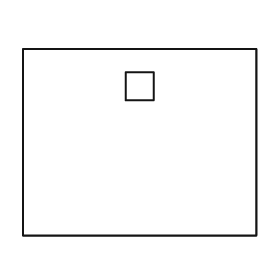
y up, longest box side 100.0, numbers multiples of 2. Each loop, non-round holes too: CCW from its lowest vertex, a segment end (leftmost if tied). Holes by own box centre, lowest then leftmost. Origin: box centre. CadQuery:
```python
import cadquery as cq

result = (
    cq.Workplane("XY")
    .moveTo(-50.0, -40.0)
    .lineTo(50.0, -40.0)
    .lineTo(50.0, 40.0)
    .lineTo(-50.0, 40.0)
    .close()
    .moveTo(-6.0, 18.0)
    .lineTo(6.0, 18.0)
    .lineTo(6.0, 30.0)
    .lineTo(-6.0, 30.0)
    .close()
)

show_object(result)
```